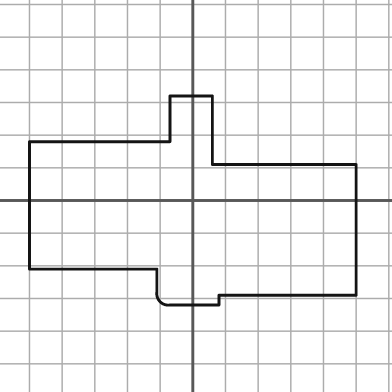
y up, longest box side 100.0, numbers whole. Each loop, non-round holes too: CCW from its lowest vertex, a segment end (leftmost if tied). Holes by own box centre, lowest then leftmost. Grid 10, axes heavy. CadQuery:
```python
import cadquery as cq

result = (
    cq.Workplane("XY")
    .moveTo(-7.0, -32.0)
    .lineTo(8.0, -32.0)
    .lineTo(8.0, -29.0)
    .lineTo(50.0, -29.0)
    .lineTo(50.0, 11.0)
    .lineTo(6.0, 11.0)
    .lineTo(6.0, 32.0)
    .lineTo(-7.0, 32.0)
    .lineTo(-7.0, 18.0)
    .lineTo(-50.0, 18.0)
    .lineTo(-50.0, -21.0)
    .lineTo(-11.0, -21.0)
    .lineTo(-11.0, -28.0)
    .threePointArc((-10.0, -31.0), (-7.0, -32.0))
    .close()
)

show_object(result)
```